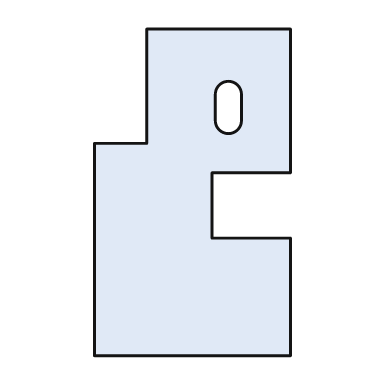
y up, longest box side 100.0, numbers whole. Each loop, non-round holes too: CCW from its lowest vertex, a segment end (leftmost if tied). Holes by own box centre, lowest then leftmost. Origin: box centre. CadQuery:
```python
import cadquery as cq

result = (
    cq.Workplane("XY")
    .moveTo(-30.0, -50.0)
    .lineTo(30.0, -50.0)
    .lineTo(30.0, -14.0)
    .lineTo(6.0, -14.0)
    .lineTo(6.0, 6.0)
    .lineTo(30.0, 6.0)
    .lineTo(30.0, 50.0)
    .lineTo(-14.0, 50.0)
    .lineTo(-14.0, 15.0)
    .lineTo(-30.0, 15.0)
    .close()
    .moveTo(7.0, 22.0)
    .threePointArc((11.0, 18.0), (15.0, 22.0))
    .lineTo(15.0, 30.0)
    .threePointArc((11.0, 34.0), (7.0, 30.0))
    .close()
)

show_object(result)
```